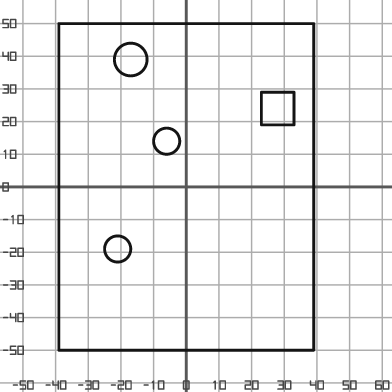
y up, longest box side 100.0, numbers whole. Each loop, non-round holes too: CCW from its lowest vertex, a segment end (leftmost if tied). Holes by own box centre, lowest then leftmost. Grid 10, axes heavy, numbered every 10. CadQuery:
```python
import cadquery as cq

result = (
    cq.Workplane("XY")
    .moveTo(-39.0, -50.0)
    .lineTo(39.0, -50.0)
    .lineTo(39.0, 50.0)
    .lineTo(-39.0, 50.0)
    .close()
    .moveTo(-21.0, -19.0)
    .circle(4.0)
    .moveTo(-6.0, 14.0)
    .circle(4.0)
    .moveTo(23.0, 19.0)
    .lineTo(33.0, 19.0)
    .lineTo(33.0, 29.0)
    .lineTo(23.0, 29.0)
    .close()
    .moveTo(-17.0, 39.0)
    .circle(5.0)
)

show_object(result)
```